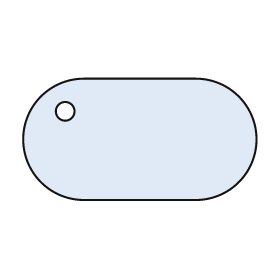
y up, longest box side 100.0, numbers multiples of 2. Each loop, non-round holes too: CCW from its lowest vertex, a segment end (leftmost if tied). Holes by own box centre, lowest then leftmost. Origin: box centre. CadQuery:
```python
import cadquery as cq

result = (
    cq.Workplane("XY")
    .moveTo(-24.0, -26.0)
    .lineTo(24.0, -26.0)
    .threePointArc((50.0, 0.0), (24.0, 26.0))
    .lineTo(-24.0, 26.0)
    .threePointArc((-50.0, 0.0), (-24.0, -26.0))
    .close()
    .moveTo(-32.0, 12.0)
    .circle(4.0)
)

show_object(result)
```